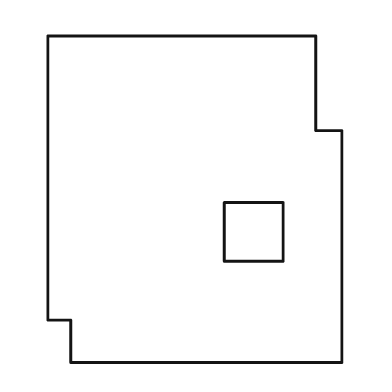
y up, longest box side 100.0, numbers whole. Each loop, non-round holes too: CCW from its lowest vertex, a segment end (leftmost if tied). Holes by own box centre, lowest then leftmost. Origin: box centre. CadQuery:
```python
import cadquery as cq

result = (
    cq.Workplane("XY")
    .moveTo(-38.0, -50.0)
    .lineTo(45.0, -50.0)
    .lineTo(45.0, 21.0)
    .lineTo(37.0, 21.0)
    .lineTo(37.0, 50.0)
    .lineTo(-45.0, 50.0)
    .lineTo(-45.0, -37.0)
    .lineTo(-38.0, -37.0)
    .close()
    .moveTo(9.0, -19.0)
    .lineTo(27.0, -19.0)
    .lineTo(27.0, -1.0)
    .lineTo(9.0, -1.0)
    .close()
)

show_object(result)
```